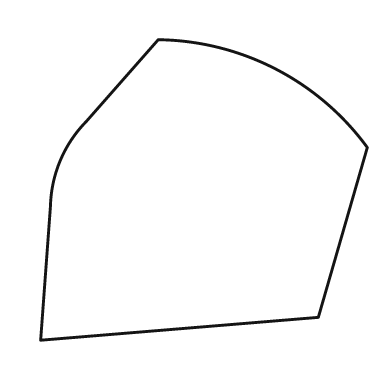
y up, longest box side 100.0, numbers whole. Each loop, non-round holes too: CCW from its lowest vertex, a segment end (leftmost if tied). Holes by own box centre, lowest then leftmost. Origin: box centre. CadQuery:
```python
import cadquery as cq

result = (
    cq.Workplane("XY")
    .moveTo(-50.0, -46.0)
    .lineTo(35.0, -39.0)
    .lineTo(50.0, 13.0)
    .threePointArc((22.0, 37.0), (-14.0, 46.0))
    .lineTo(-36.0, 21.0)
    .threePointArc((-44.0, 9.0), (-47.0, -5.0))
    .close()
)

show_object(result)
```